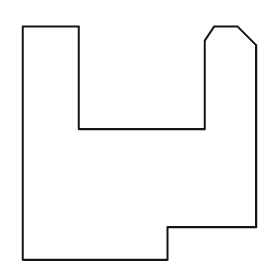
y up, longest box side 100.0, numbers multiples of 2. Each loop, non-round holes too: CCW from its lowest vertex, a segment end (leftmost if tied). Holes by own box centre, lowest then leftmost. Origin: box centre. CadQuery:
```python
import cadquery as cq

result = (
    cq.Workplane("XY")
    .moveTo(-50.0, -50.0)
    .lineTo(12.0, -50.0)
    .lineTo(12.0, -36.0)
    .lineTo(50.0, -36.0)
    .lineTo(50.0, 42.0)
    .lineTo(42.0, 50.0)
    .lineTo(32.0, 50.0)
    .lineTo(28.0, 44.0)
    .lineTo(28.0, 6.0)
    .lineTo(-26.0, 6.0)
    .lineTo(-26.0, 50.0)
    .lineTo(-50.0, 50.0)
    .close()
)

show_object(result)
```